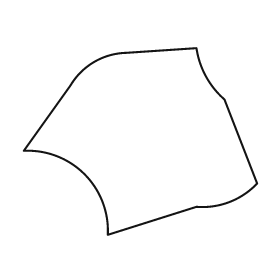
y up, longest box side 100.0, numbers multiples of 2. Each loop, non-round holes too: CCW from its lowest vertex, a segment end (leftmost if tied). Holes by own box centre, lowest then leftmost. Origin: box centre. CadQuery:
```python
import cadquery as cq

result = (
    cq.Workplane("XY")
    .moveTo(-14.0, -40.0)
    .lineTo(24.0, -28.0)
    .threePointArc((38.0, -26.0), (50.0, -18.0))
    .lineTo(36.0, 18.0)
    .threePointArc((28.0, 28.0), (24.0, 40.0))
    .lineTo(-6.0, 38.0)
    .threePointArc((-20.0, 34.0), (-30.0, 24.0))
    .lineTo(-50.0, -4.0)
    .threePointArc((-24.0, -14.0), (-14.0, -40.0))
    .close()
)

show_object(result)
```